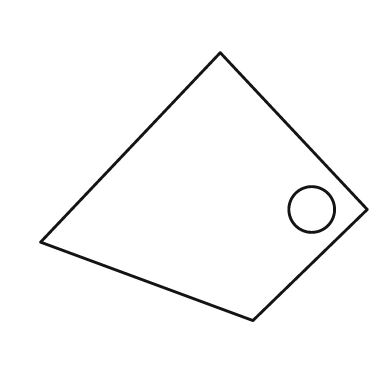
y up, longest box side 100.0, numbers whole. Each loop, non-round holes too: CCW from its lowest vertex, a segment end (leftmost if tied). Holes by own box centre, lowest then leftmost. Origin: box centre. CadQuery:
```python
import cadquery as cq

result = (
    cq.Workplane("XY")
    .moveTo(15.0, -41.0)
    .lineTo(50.0, -7.0)
    .lineTo(5.0, 41.0)
    .lineTo(-50.0, -17.0)
    .close()
    .moveTo(33.0, -7.0)
    .circle(7.0)
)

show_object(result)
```